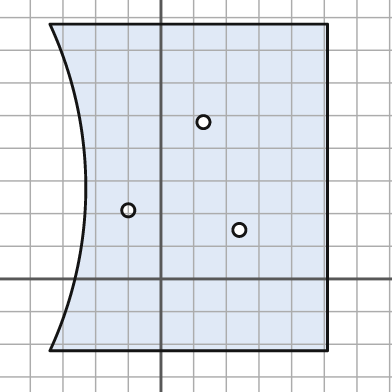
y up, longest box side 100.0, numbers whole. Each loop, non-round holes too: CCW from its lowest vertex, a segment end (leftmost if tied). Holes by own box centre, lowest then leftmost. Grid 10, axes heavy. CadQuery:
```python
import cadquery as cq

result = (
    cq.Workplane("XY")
    .moveTo(-34.0, -22.0)
    .lineTo(51.0, -22.0)
    .lineTo(51.0, 78.0)
    .lineTo(-34.0, 78.0)
    .threePointArc((-23.0, 28.0), (-34.0, -22.0))
    .close()
    .moveTo(24.0, 15.0)
    .circle(2.0)
    .moveTo(-10.0, 21.0)
    .circle(2.0)
    .moveTo(13.0, 48.0)
    .circle(2.0)
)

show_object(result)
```